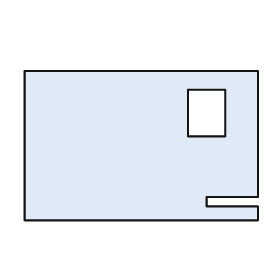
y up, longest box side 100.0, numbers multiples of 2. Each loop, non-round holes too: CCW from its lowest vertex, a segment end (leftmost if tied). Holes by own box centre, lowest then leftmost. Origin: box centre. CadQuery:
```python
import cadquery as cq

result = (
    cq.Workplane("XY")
    .moveTo(-50.0, -32.0)
    .lineTo(50.0, -32.0)
    .lineTo(50.0, -26.0)
    .lineTo(28.0, -26.0)
    .lineTo(28.0, -22.0)
    .lineTo(50.0, -22.0)
    .lineTo(50.0, 32.0)
    .lineTo(-50.0, 32.0)
    .close()
    .moveTo(20.0, 4.0)
    .lineTo(36.0, 4.0)
    .lineTo(36.0, 24.0)
    .lineTo(20.0, 24.0)
    .close()
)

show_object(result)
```